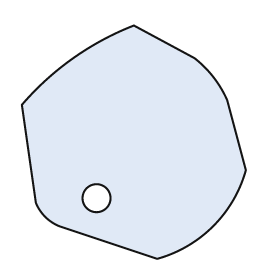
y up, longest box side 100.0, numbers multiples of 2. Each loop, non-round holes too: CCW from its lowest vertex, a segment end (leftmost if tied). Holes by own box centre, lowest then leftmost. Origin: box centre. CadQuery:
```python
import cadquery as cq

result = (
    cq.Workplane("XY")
    .moveTo(10.0, -50.0)
    .threePointArc((34.0, -36.0), (48.0, -12.0))
    .lineTo(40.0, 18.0)
    .threePointArc((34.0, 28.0), (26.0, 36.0))
    .lineTo(0.0, 50.0)
    .threePointArc((-26.0, 36.0), (-48.0, 16.0))
    .lineTo(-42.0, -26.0)
    .threePointArc((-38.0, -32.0), (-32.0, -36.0))
    .close()
    .moveTo(-16.0, -24.0)
    .circle(6.0)
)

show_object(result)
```